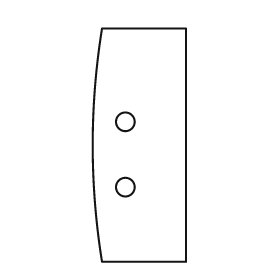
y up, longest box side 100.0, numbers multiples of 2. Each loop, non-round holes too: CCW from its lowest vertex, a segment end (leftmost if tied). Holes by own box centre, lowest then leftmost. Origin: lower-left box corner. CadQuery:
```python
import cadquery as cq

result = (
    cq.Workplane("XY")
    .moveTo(4.0, 0.0)
    .lineTo(40.0, 0.0)
    .lineTo(40.0, 100.0)
    .lineTo(4.0, 100.0)
    .threePointArc((0.0, 50.0), (4.0, 0.0))
    .close()
    .moveTo(14.0, 32.0)
    .circle(4.0)
    .moveTo(14.0, 60.0)
    .circle(4.0)
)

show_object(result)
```